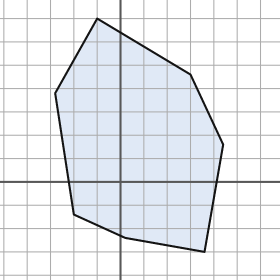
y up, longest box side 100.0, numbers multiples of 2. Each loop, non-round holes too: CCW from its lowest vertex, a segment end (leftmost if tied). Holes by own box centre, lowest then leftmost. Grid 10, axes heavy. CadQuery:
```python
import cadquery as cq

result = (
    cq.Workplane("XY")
    .moveTo(36.0, -30.0)
    .lineTo(44.0, 16.0)
    .lineTo(30.0, 46.0)
    .lineTo(-10.0, 70.0)
    .lineTo(-28.0, 38.0)
    .lineTo(-20.0, -14.0)
    .lineTo(2.0, -24.0)
    .close()
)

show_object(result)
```